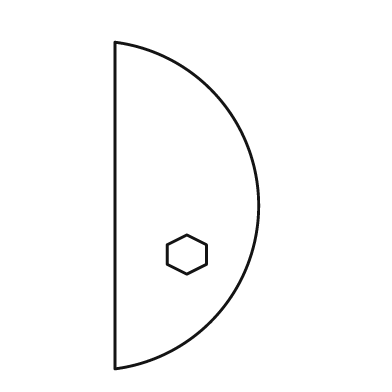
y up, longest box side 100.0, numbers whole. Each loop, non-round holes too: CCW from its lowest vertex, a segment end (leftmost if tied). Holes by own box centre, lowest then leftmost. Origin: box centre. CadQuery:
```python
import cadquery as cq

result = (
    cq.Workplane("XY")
    .moveTo(-22.0, -50.0)
    .threePointArc((22.0, 0.0), (-22.0, 50.0))
    .close()
    .moveTo(0.0, -21.0)
    .lineTo(6.0, -18.0)
    .lineTo(6.0, -12.0)
    .lineTo(0.0, -9.0)
    .lineTo(-6.0, -12.0)
    .lineTo(-6.0, -18.0)
    .close()
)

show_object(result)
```